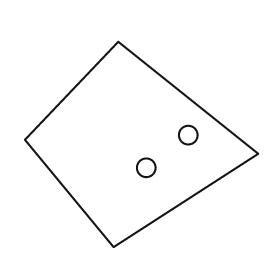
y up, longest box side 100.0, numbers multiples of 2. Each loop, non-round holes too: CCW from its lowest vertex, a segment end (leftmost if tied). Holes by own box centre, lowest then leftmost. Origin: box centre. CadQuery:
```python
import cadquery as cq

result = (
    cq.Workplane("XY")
    .moveTo(-12.0, -44.0)
    .lineTo(50.0, -4.0)
    .lineTo(-10.0, 44.0)
    .lineTo(-50.0, 2.0)
    .close()
    .moveTo(2.0, -10.0)
    .circle(4.0)
    .moveTo(20.0, 4.0)
    .circle(4.0)
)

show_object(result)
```